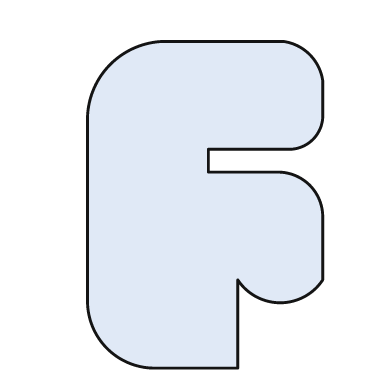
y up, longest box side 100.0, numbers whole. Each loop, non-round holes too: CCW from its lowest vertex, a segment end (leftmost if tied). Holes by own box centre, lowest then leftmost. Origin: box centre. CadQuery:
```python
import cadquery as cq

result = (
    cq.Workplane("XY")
    .moveTo(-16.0, -50.0)
    .lineTo(10.0, -50.0)
    .lineTo(10.0, -23.0)
    .threePointArc((23.0, -30.0), (36.0, -23.0))
    .lineTo(36.0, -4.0)
    .threePointArc((32.0, 6.0), (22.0, 10.0))
    .lineTo(1.0, 10.0)
    .lineTo(1.0, 17.0)
    .lineTo(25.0, 17.0)
    .threePointArc((33.0, 20.0), (36.0, 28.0))
    .lineTo(36.0, 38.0)
    .threePointArc((32.0, 46.0), (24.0, 50.0))
    .lineTo(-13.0, 50.0)
    .threePointArc((-29.0, 43.0), (-36.0, 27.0))
    .lineTo(-36.0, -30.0)
    .threePointArc((-30.0, -44.0), (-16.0, -50.0))
    .close()
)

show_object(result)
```